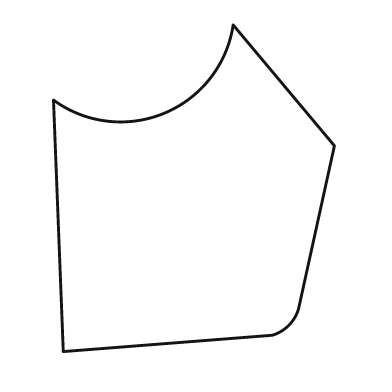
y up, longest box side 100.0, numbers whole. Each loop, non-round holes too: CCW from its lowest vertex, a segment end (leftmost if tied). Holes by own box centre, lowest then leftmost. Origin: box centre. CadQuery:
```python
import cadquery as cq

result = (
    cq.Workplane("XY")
    .moveTo(-40.0, -50.0)
    .lineTo(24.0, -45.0)
    .threePointArc((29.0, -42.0), (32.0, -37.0))
    .lineTo(43.0, 13.0)
    .lineTo(12.0, 50.0)
    .threePointArc((-9.0, 23.0), (-43.0, 27.0))
    .close()
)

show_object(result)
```